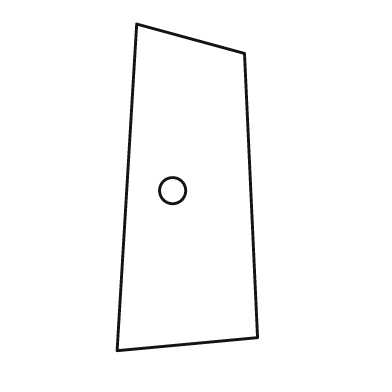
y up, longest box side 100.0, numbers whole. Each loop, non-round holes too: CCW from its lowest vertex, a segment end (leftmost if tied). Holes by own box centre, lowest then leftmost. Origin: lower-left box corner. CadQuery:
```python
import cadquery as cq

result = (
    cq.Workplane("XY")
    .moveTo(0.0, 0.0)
    .lineTo(43.0, 4.0)
    .lineTo(39.0, 91.0)
    .lineTo(6.0, 100.0)
    .close()
    .moveTo(17.0, 49.0)
    .circle(4.0)
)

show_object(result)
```